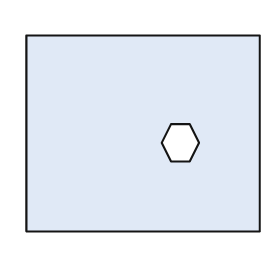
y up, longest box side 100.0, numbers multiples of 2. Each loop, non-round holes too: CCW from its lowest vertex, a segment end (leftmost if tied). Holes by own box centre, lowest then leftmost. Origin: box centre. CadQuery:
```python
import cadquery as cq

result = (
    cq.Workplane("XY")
    .moveTo(-50.0, -42.0)
    .lineTo(50.0, -42.0)
    .lineTo(50.0, 42.0)
    .lineTo(-50.0, 42.0)
    .close()
    .moveTo(12.0, -12.0)
    .lineTo(20.0, -12.0)
    .lineTo(24.0, -4.0)
    .lineTo(20.0, 4.0)
    .lineTo(12.0, 4.0)
    .lineTo(8.0, -4.0)
    .close()
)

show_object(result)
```